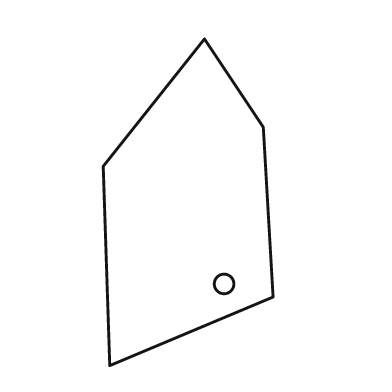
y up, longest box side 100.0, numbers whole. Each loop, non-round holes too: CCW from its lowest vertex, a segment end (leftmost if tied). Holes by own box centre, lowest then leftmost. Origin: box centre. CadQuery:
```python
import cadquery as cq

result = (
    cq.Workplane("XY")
    .moveTo(-24.0, -50.0)
    .lineTo(26.0, -29.0)
    .lineTo(23.0, 23.0)
    .lineTo(5.0, 50.0)
    .lineTo(-26.0, 11.0)
    .close()
    .moveTo(11.0, -25.0)
    .circle(3.0)
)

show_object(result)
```